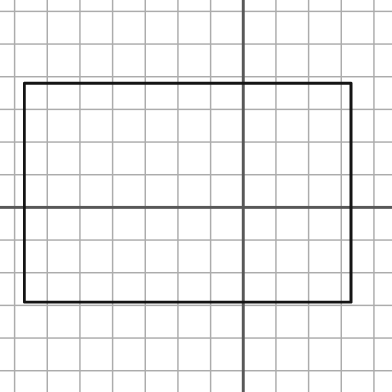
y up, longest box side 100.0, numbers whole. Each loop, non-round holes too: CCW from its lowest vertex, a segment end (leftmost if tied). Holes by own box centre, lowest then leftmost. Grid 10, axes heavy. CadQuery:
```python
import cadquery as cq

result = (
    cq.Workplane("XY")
    .moveTo(-67.0, -29.0)
    .lineTo(33.0, -29.0)
    .lineTo(33.0, 38.0)
    .lineTo(-67.0, 38.0)
    .close()
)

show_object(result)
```